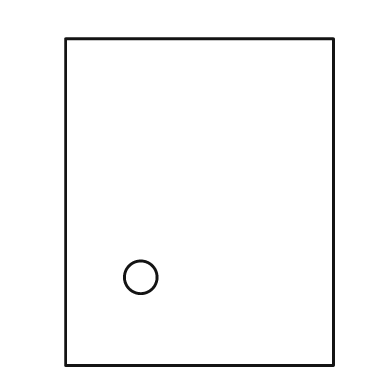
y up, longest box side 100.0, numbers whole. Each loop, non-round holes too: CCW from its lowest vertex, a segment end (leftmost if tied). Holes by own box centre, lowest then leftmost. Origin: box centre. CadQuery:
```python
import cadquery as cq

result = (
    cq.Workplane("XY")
    .moveTo(-41.0, -50.0)
    .lineTo(41.0, -50.0)
    .lineTo(41.0, 50.0)
    .lineTo(-41.0, 50.0)
    .close()
    .moveTo(-18.0, -23.0)
    .circle(5.0)
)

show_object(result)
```